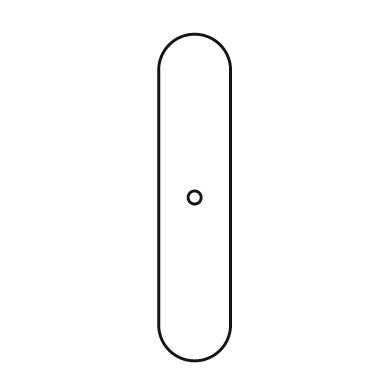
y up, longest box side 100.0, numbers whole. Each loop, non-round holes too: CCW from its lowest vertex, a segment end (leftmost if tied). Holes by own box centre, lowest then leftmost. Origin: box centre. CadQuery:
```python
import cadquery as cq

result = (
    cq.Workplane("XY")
    .moveTo(-11.0, -39.0)
    .threePointArc((0.0, -50.0), (11.0, -39.0))
    .lineTo(11.0, 39.0)
    .threePointArc((0.0, 50.0), (-11.0, 39.0))
    .close()
    .moveTo(0.0, 0.0)
    .circle(2.0)
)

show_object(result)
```